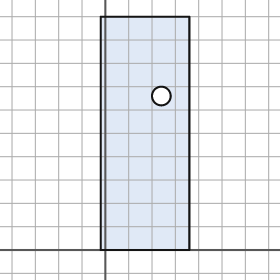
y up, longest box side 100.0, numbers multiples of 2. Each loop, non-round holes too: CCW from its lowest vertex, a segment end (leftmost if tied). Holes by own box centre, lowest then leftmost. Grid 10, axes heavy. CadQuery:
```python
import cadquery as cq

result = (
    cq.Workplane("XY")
    .moveTo(-2.0, 0.0)
    .lineTo(36.0, 0.0)
    .lineTo(36.0, 100.0)
    .lineTo(-2.0, 100.0)
    .close()
    .moveTo(24.0, 66.0)
    .circle(4.0)
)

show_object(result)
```